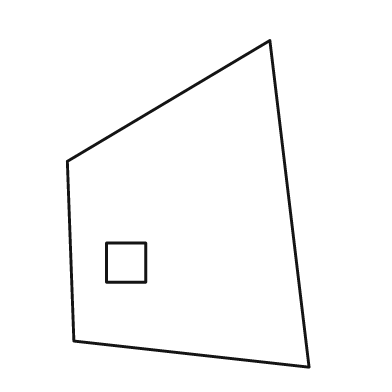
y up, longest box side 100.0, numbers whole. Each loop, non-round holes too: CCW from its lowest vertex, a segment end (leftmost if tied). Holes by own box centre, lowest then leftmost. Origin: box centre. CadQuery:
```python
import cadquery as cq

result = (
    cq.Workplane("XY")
    .moveTo(37.0, -50.0)
    .lineTo(25.0, 50.0)
    .lineTo(-37.0, 13.0)
    .lineTo(-35.0, -42.0)
    .close()
    .moveTo(-25.0, -24.0)
    .lineTo(-13.0, -24.0)
    .lineTo(-13.0, -12.0)
    .lineTo(-25.0, -12.0)
    .close()
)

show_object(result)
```